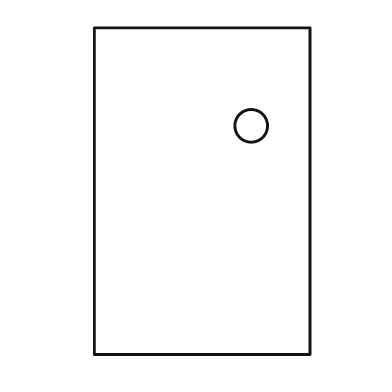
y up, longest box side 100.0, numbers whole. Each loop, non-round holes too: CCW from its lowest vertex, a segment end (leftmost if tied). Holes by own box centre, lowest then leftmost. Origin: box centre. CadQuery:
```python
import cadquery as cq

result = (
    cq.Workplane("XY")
    .moveTo(-33.0, -50.0)
    .lineTo(33.0, -50.0)
    .lineTo(33.0, 50.0)
    .lineTo(-33.0, 50.0)
    .close()
    .moveTo(15.0, 20.0)
    .circle(5.0)
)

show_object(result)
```